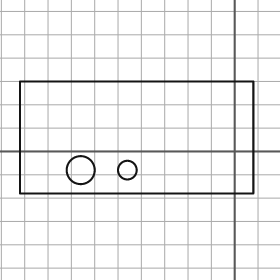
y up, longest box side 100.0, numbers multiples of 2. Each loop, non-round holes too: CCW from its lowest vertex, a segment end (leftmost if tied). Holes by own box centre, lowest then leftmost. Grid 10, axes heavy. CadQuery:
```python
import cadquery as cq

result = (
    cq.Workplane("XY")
    .moveTo(-92.0, -18.0)
    .lineTo(8.0, -18.0)
    .lineTo(8.0, 30.0)
    .lineTo(-92.0, 30.0)
    .close()
    .moveTo(-66.0, -8.0)
    .circle(6.0)
    .moveTo(-46.0, -8.0)
    .circle(4.0)
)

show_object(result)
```